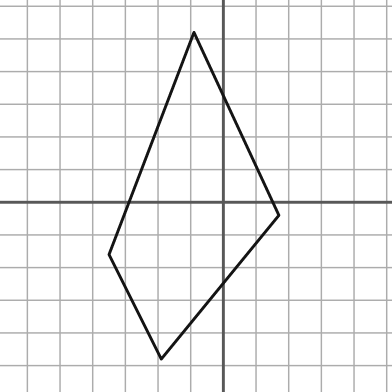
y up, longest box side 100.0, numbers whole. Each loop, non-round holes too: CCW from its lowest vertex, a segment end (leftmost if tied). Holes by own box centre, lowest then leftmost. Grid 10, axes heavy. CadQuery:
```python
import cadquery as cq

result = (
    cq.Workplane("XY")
    .moveTo(-19.0, -48.0)
    .lineTo(17.0, -4.0)
    .lineTo(-9.0, 52.0)
    .lineTo(-35.0, -16.0)
    .close()
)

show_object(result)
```